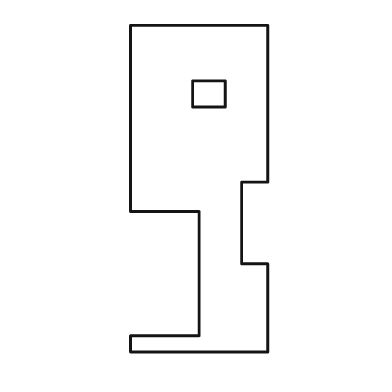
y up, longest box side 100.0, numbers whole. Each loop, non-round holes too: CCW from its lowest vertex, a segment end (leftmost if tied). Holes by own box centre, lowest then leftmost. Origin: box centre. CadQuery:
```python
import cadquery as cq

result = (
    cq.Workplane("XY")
    .moveTo(-21.0, -50.0)
    .lineTo(21.0, -50.0)
    .lineTo(21.0, -23.0)
    .lineTo(13.0, -23.0)
    .lineTo(13.0, 2.0)
    .lineTo(21.0, 2.0)
    .lineTo(21.0, 50.0)
    .lineTo(-21.0, 50.0)
    .lineTo(-21.0, -7.0)
    .lineTo(0.0, -7.0)
    .lineTo(0.0, -45.0)
    .lineTo(-21.0, -45.0)
    .close()
    .moveTo(-2.0, 25.0)
    .lineTo(8.0, 25.0)
    .lineTo(8.0, 33.0)
    .lineTo(-2.0, 33.0)
    .close()
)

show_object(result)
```